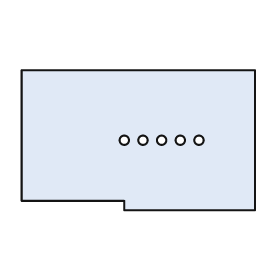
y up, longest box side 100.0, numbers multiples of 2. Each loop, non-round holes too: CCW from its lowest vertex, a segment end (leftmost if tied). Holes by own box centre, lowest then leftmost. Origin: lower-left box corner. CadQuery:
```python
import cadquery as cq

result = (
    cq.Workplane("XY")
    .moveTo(44.0, 0.0)
    .lineTo(100.0, 0.0)
    .lineTo(100.0, 60.0)
    .lineTo(0.0, 60.0)
    .lineTo(0.0, 4.0)
    .lineTo(44.0, 4.0)
    .close()
    .moveTo(44.0, 30.0)
    .circle(2.0)
    .moveTo(52.0, 30.0)
    .circle(2.0)
    .moveTo(60.0, 30.0)
    .circle(2.0)
    .moveTo(68.0, 30.0)
    .circle(2.0)
    .moveTo(76.0, 30.0)
    .circle(2.0)
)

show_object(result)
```